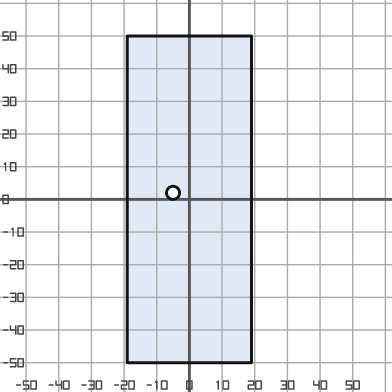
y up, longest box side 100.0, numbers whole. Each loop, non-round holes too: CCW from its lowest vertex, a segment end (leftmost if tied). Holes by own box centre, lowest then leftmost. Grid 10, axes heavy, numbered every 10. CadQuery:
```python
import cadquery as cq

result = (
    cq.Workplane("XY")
    .moveTo(-19.0, -50.0)
    .lineTo(19.0, -50.0)
    .lineTo(19.0, 50.0)
    .lineTo(-19.0, 50.0)
    .close()
    .moveTo(-5.0, 2.0)
    .circle(2.0)
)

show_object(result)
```